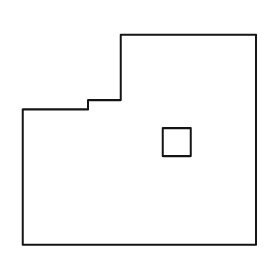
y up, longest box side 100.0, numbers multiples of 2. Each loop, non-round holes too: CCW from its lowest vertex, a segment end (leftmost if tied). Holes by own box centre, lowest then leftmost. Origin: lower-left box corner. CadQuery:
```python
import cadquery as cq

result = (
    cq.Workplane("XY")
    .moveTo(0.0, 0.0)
    .lineTo(100.0, 0.0)
    .lineTo(100.0, 90.0)
    .lineTo(42.0, 90.0)
    .lineTo(42.0, 62.0)
    .lineTo(28.0, 62.0)
    .lineTo(28.0, 58.0)
    .lineTo(0.0, 58.0)
    .close()
    .moveTo(60.0, 38.0)
    .lineTo(72.0, 38.0)
    .lineTo(72.0, 50.0)
    .lineTo(60.0, 50.0)
    .close()
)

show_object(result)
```